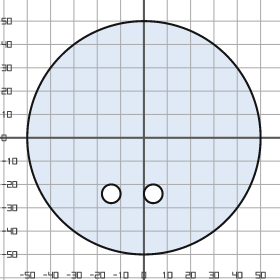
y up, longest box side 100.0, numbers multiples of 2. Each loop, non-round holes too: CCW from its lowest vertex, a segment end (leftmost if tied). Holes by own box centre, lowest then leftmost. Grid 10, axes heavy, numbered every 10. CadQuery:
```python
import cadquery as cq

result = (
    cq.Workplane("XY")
    .moveTo(0.0, 0.0)
    .circle(50.0)
    .moveTo(-14.0, -24.0)
    .circle(4.0)
    .moveTo(4.0, -24.0)
    .circle(4.0)
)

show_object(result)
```